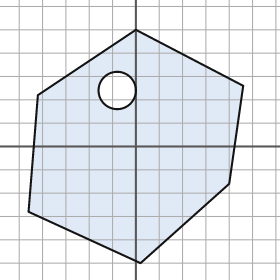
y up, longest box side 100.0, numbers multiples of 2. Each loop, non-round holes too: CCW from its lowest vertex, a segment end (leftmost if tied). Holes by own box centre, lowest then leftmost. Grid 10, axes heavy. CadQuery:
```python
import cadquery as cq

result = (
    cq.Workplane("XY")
    .moveTo(2.0, -50.0)
    .lineTo(40.0, -16.0)
    .lineTo(46.0, 26.0)
    .lineTo(0.0, 50.0)
    .lineTo(-42.0, 22.0)
    .lineTo(-46.0, -28.0)
    .close()
    .moveTo(-8.0, 24.0)
    .circle(8.0)
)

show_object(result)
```